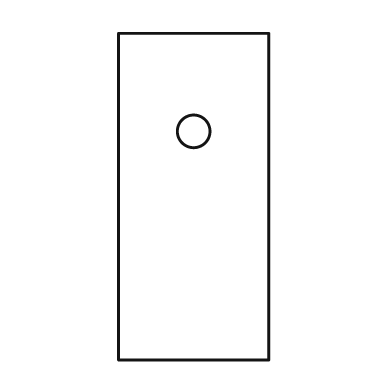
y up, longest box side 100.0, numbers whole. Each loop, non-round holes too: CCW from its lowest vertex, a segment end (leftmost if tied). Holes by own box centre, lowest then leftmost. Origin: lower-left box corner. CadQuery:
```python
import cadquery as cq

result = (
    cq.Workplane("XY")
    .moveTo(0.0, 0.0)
    .lineTo(46.0, 0.0)
    .lineTo(46.0, 100.0)
    .lineTo(0.0, 100.0)
    .close()
    .moveTo(23.0, 70.0)
    .circle(5.0)
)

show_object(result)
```